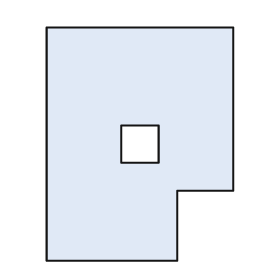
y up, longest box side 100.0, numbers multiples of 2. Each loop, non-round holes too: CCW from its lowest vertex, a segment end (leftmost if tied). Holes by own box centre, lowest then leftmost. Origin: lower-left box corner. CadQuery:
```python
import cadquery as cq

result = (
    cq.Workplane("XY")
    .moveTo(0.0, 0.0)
    .lineTo(56.0, 0.0)
    .lineTo(56.0, 30.0)
    .lineTo(80.0, 30.0)
    .lineTo(80.0, 100.0)
    .lineTo(0.0, 100.0)
    .close()
    .moveTo(32.0, 42.0)
    .lineTo(48.0, 42.0)
    .lineTo(48.0, 58.0)
    .lineTo(32.0, 58.0)
    .close()
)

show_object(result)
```